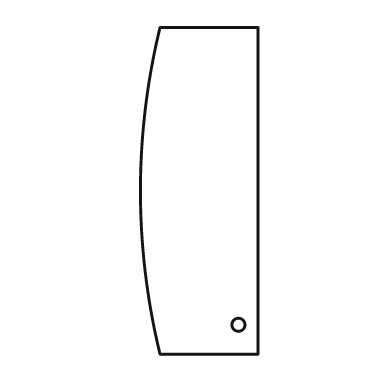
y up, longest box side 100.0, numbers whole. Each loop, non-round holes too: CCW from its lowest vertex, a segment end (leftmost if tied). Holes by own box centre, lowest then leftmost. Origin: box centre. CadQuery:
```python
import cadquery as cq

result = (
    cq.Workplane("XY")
    .moveTo(-12.0, -50.0)
    .lineTo(18.0, -50.0)
    .lineTo(18.0, 50.0)
    .lineTo(-12.0, 50.0)
    .threePointArc((-18.0, 0.0), (-12.0, -50.0))
    .close()
    .moveTo(12.0, -41.0)
    .circle(2.0)
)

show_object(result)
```